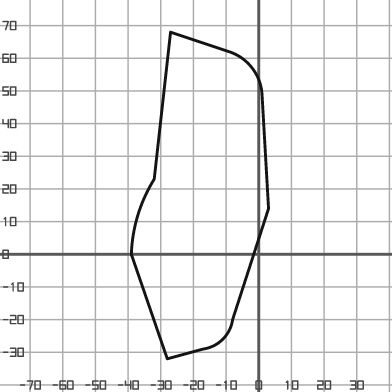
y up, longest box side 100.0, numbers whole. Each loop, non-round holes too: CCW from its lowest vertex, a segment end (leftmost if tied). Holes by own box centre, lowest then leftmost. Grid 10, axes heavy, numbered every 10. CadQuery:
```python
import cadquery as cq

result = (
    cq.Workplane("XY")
    .moveTo(-28.0, -32.0)
    .lineTo(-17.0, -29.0)
    .threePointArc((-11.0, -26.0), (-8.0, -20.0))
    .lineTo(3.0, 14.0)
    .lineTo(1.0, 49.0)
    .threePointArc((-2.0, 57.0), (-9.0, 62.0))
    .lineTo(-27.0, 68.0)
    .lineTo(-32.0, 23.0)
    .threePointArc((-37.0, 12.0), (-39.0, 0.0))
    .close()
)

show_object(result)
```